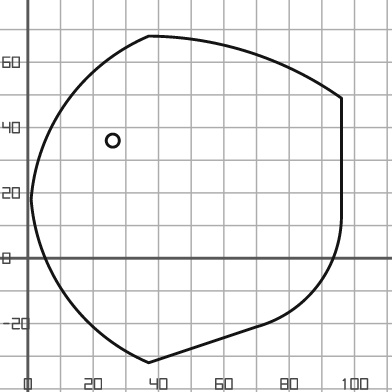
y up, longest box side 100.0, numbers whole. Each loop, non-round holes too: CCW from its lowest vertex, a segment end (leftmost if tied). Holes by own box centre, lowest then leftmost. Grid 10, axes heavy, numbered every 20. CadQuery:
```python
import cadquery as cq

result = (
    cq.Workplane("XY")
    .moveTo(37.0, -32.0)
    .lineTo(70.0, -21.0)
    .threePointArc((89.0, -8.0), (96.0, 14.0))
    .lineTo(96.0, 49.0)
    .threePointArc((68.0, 63.0), (37.0, 68.0))
    .threePointArc((12.0, 48.0), (1.0, 18.0))
    .threePointArc((12.0, -12.0), (37.0, -32.0))
    .close()
    .moveTo(26.0, 36.0)
    .circle(2.0)
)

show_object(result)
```